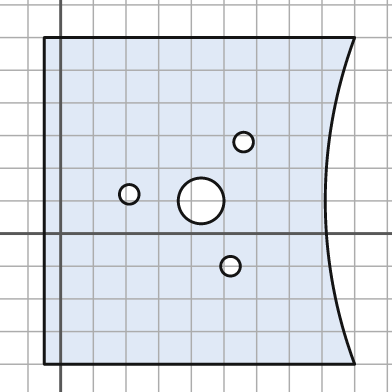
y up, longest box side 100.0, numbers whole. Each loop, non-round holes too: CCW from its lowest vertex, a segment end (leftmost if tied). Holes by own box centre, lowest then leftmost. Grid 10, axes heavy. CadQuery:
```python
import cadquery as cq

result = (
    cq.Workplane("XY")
    .moveTo(-5.0, -40.0)
    .lineTo(90.0, -40.0)
    .threePointArc((81.0, 10.0), (90.0, 60.0))
    .lineTo(-5.0, 60.0)
    .close()
    .moveTo(52.0, -10.0)
    .circle(3.0)
    .moveTo(43.0, 10.0)
    .circle(7.0)
    .moveTo(21.0, 12.0)
    .circle(3.0)
    .moveTo(56.0, 28.0)
    .circle(3.0)
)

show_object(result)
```